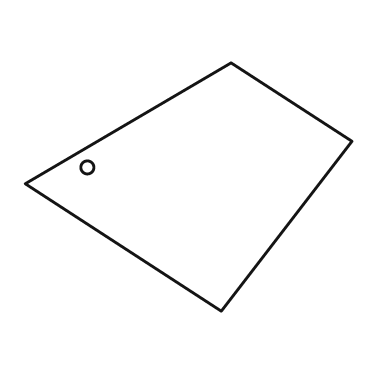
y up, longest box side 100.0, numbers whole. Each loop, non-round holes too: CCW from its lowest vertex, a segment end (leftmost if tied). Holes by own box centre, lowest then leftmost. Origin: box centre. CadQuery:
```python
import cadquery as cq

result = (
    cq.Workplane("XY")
    .moveTo(10.0, -38.0)
    .lineTo(50.0, 14.0)
    .lineTo(13.0, 38.0)
    .lineTo(-50.0, 1.0)
    .close()
    .moveTo(-31.0, 6.0)
    .circle(2.0)
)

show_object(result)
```